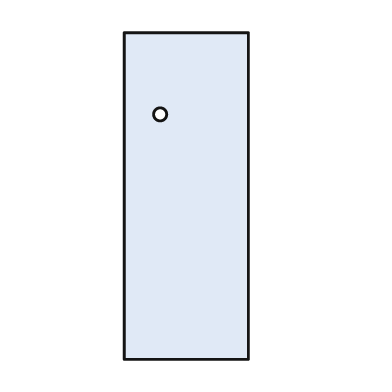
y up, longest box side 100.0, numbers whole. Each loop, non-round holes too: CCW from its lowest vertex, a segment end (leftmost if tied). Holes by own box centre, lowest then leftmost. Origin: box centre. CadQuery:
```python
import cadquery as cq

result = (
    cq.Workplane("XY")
    .moveTo(-19.0, -50.0)
    .lineTo(19.0, -50.0)
    .lineTo(19.0, 50.0)
    .lineTo(-19.0, 50.0)
    .close()
    .moveTo(-8.0, 25.0)
    .circle(2.0)
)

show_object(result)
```